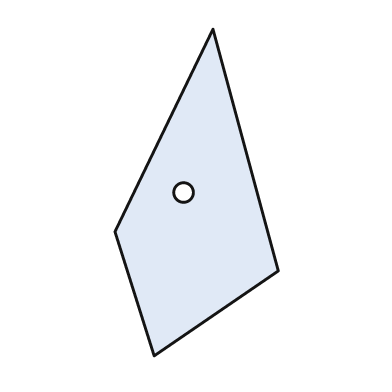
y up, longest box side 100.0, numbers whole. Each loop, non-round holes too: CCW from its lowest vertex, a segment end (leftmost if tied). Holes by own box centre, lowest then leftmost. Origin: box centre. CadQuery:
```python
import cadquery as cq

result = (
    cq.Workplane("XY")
    .moveTo(-13.0, -50.0)
    .lineTo(25.0, -24.0)
    .lineTo(5.0, 50.0)
    .lineTo(-25.0, -12.0)
    .close()
    .moveTo(-4.0, 0.0)
    .circle(3.0)
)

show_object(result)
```